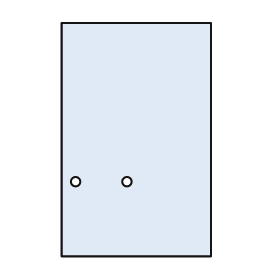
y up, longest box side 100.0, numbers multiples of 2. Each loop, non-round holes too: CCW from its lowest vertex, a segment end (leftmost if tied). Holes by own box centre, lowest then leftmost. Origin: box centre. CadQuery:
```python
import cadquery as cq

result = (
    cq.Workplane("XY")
    .moveTo(-32.0, -50.0)
    .lineTo(32.0, -50.0)
    .lineTo(32.0, 50.0)
    .lineTo(-32.0, 50.0)
    .close()
    .moveTo(-26.0, -18.0)
    .circle(2.0)
    .moveTo(-4.0, -18.0)
    .circle(2.0)
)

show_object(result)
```